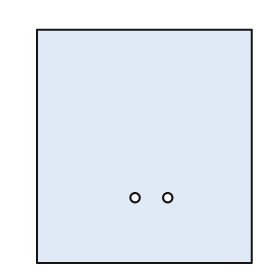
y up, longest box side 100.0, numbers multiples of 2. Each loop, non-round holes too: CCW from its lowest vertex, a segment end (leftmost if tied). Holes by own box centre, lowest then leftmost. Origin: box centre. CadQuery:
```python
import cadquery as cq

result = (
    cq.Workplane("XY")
    .moveTo(-46.0, -50.0)
    .lineTo(46.0, -50.0)
    .lineTo(46.0, 50.0)
    .lineTo(-46.0, 50.0)
    .close()
    .moveTo(-4.0, -22.0)
    .circle(2.0)
    .moveTo(10.0, -22.0)
    .circle(2.0)
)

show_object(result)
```